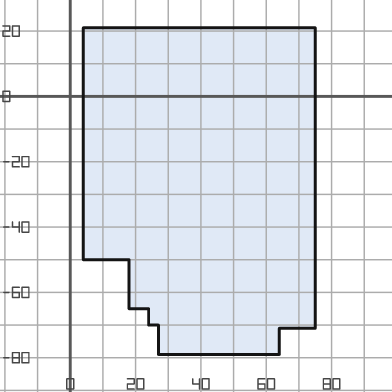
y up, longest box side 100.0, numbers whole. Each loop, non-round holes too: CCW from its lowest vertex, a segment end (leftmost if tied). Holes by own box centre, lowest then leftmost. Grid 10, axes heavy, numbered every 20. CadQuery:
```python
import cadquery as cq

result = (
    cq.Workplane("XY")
    .moveTo(27.0, -79.0)
    .lineTo(64.0, -79.0)
    .lineTo(64.0, -71.0)
    .lineTo(75.0, -71.0)
    .lineTo(75.0, 21.0)
    .lineTo(4.0, 21.0)
    .lineTo(4.0, -50.0)
    .lineTo(18.0, -50.0)
    .lineTo(18.0, -65.0)
    .lineTo(24.0, -65.0)
    .lineTo(24.0, -70.0)
    .lineTo(27.0, -70.0)
    .close()
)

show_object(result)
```